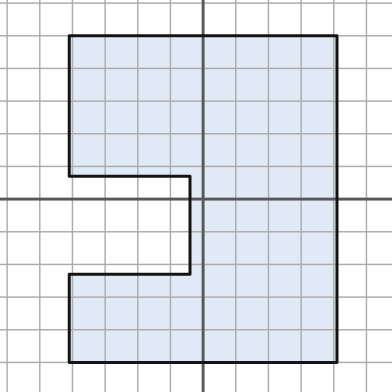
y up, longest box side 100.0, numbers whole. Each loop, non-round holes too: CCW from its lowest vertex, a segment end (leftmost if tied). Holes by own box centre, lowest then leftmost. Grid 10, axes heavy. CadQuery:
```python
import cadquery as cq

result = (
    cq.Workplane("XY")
    .moveTo(-41.0, -50.0)
    .lineTo(41.0, -50.0)
    .lineTo(41.0, 50.0)
    .lineTo(-41.0, 50.0)
    .lineTo(-41.0, 7.0)
    .lineTo(-4.0, 7.0)
    .lineTo(-4.0, -23.0)
    .lineTo(-41.0, -23.0)
    .close()
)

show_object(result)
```